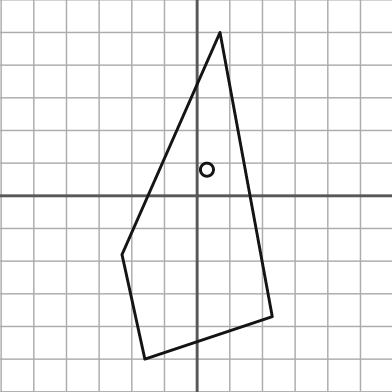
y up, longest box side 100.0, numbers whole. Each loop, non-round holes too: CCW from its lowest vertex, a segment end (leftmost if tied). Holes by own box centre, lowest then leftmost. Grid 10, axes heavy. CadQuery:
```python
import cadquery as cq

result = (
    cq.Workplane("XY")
    .moveTo(-16.0, -50.0)
    .lineTo(23.0, -37.0)
    .lineTo(7.0, 50.0)
    .lineTo(-23.0, -18.0)
    .close()
    .moveTo(3.0, 8.0)
    .circle(2.0)
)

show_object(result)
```